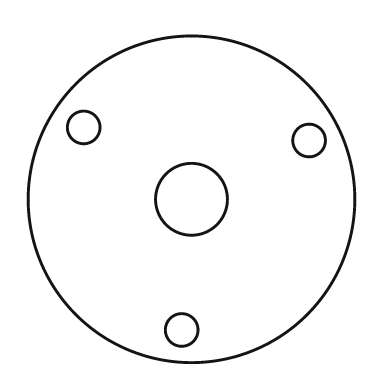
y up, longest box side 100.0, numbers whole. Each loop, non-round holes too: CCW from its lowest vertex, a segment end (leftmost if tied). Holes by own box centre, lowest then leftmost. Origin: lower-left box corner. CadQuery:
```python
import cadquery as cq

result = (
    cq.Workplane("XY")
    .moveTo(50.0, 50.0)
    .circle(50.0)
    .moveTo(47.0, 10.0)
    .circle(5.0)
    .moveTo(50.0, 50.0)
    .circle(11.0)
    .moveTo(86.0, 68.0)
    .circle(5.0)
    .moveTo(17.0, 72.0)
    .circle(5.0)
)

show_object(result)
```